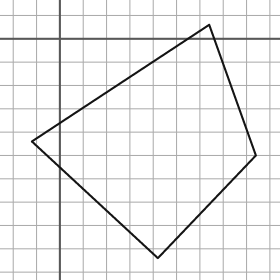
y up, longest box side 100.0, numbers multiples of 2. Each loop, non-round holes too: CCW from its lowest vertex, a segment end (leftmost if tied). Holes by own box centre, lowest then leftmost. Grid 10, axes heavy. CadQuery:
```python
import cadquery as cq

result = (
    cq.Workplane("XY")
    .moveTo(42.0, -94.0)
    .lineTo(84.0, -50.0)
    .lineTo(64.0, 6.0)
    .lineTo(-12.0, -44.0)
    .close()
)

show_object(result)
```